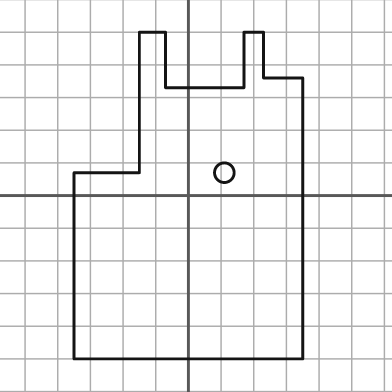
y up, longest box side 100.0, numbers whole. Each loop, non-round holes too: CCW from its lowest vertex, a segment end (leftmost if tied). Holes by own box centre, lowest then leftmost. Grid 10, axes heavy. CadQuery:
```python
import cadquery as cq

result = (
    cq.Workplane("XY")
    .moveTo(-35.0, -50.0)
    .lineTo(35.0, -50.0)
    .lineTo(35.0, 36.0)
    .lineTo(23.0, 36.0)
    .lineTo(23.0, 50.0)
    .lineTo(17.0, 50.0)
    .lineTo(17.0, 33.0)
    .lineTo(-7.0, 33.0)
    .lineTo(-7.0, 50.0)
    .lineTo(-15.0, 50.0)
    .lineTo(-15.0, 7.0)
    .lineTo(-35.0, 7.0)
    .close()
    .moveTo(11.0, 7.0)
    .circle(3.0)
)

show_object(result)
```